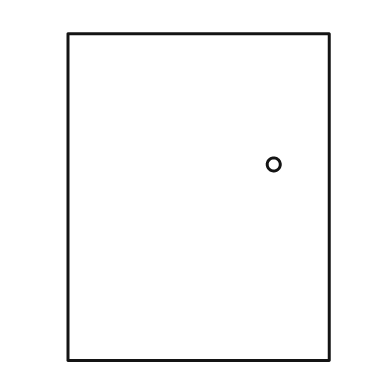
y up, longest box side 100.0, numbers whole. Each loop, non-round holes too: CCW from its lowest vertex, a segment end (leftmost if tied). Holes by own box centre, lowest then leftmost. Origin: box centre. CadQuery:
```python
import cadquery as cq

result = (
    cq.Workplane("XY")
    .moveTo(-40.0, -50.0)
    .lineTo(40.0, -50.0)
    .lineTo(40.0, 50.0)
    .lineTo(-40.0, 50.0)
    .close()
    .moveTo(23.0, 10.0)
    .circle(2.0)
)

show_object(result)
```